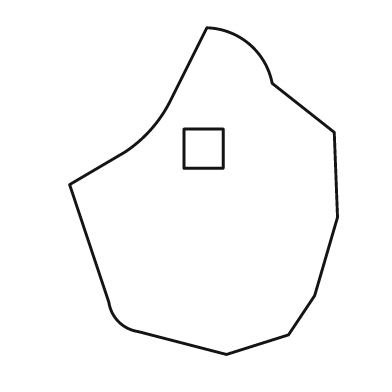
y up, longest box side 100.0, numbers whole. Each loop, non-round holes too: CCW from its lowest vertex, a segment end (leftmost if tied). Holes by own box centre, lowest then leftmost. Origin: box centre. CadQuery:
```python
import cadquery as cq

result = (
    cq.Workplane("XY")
    .moveTo(7.0, -50.0)
    .lineTo(26.0, -44.0)
    .lineTo(34.0, -32.0)
    .lineTo(41.0, -8.0)
    .lineTo(40.0, 18.0)
    .lineTo(21.0, 33.0)
    .threePointArc((14.0, 45.0), (1.0, 50.0))
    .lineTo(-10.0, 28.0)
    .threePointArc((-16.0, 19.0), (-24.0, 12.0))
    .lineTo(-41.0, 2.0)
    .lineTo(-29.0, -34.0)
    .threePointArc((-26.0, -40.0), (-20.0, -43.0))
    .close()
    .moveTo(-6.0, 7.0)
    .lineTo(6.0, 7.0)
    .lineTo(6.0, 19.0)
    .lineTo(-6.0, 19.0)
    .close()
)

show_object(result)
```